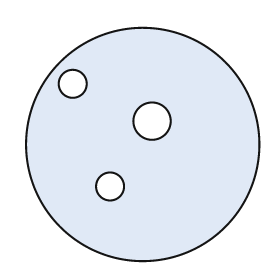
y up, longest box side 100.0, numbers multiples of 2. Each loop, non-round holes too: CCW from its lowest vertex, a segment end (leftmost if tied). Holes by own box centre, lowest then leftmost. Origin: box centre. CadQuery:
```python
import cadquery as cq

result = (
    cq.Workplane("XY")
    .moveTo(0.0, 0.0)
    .circle(50.0)
    .moveTo(-14.0, -18.0)
    .circle(6.0)
    .moveTo(4.0, 10.0)
    .circle(8.0)
    .moveTo(-30.0, 26.0)
    .circle(6.0)
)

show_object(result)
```